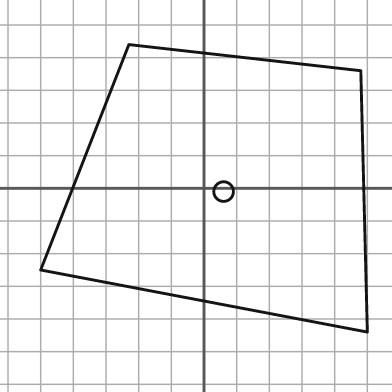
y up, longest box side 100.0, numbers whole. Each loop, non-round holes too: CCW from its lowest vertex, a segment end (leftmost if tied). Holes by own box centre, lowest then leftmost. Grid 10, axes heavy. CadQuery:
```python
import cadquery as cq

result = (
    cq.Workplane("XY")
    .moveTo(50.0, -44.0)
    .lineTo(48.0, 36.0)
    .lineTo(-23.0, 44.0)
    .lineTo(-50.0, -25.0)
    .close()
    .moveTo(6.0, -1.0)
    .circle(3.0)
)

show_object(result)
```